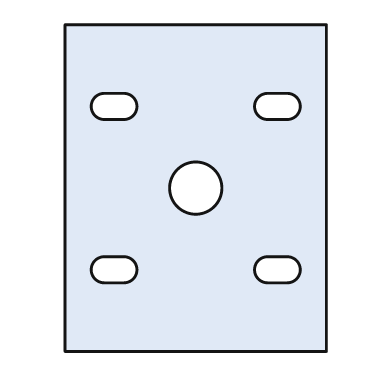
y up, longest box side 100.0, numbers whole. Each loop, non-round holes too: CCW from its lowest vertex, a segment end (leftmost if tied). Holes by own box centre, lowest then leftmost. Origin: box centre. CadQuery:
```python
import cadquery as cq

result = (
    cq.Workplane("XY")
    .moveTo(-40.0, -50.0)
    .lineTo(40.0, -50.0)
    .lineTo(40.0, 50.0)
    .lineTo(-40.0, 50.0)
    .close()
    .moveTo(-28.0, -29.0)
    .lineTo(-22.0, -29.0)
    .threePointArc((-18.0, -25.0), (-22.0, -21.0))
    .lineTo(-28.0, -21.0)
    .threePointArc((-32.0, -25.0), (-28.0, -29.0))
    .close()
    .moveTo(22.0, -29.0)
    .lineTo(28.0, -29.0)
    .threePointArc((32.0, -25.0), (28.0, -21.0))
    .lineTo(22.0, -21.0)
    .threePointArc((18.0, -25.0), (22.0, -29.0))
    .close()
    .moveTo(0.0, 0.0)
    .circle(8.0)
    .moveTo(-28.0, 21.0)
    .lineTo(-22.0, 21.0)
    .threePointArc((-18.0, 25.0), (-22.0, 29.0))
    .lineTo(-28.0, 29.0)
    .threePointArc((-32.0, 25.0), (-28.0, 21.0))
    .close()
    .moveTo(22.0, 21.0)
    .lineTo(28.0, 21.0)
    .threePointArc((32.0, 25.0), (28.0, 29.0))
    .lineTo(22.0, 29.0)
    .threePointArc((18.0, 25.0), (22.0, 21.0))
    .close()
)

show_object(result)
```